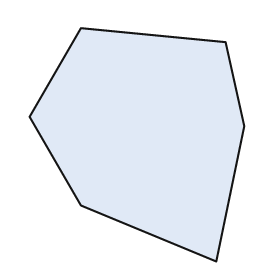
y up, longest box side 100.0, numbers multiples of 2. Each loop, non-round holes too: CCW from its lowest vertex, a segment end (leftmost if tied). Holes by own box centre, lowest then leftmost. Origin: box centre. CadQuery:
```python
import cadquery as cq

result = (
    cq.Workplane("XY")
    .moveTo(34.0, -50.0)
    .lineTo(46.0, 8.0)
    .lineTo(38.0, 44.0)
    .lineTo(-24.0, 50.0)
    .lineTo(-46.0, 12.0)
    .lineTo(-24.0, -26.0)
    .close()
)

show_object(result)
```